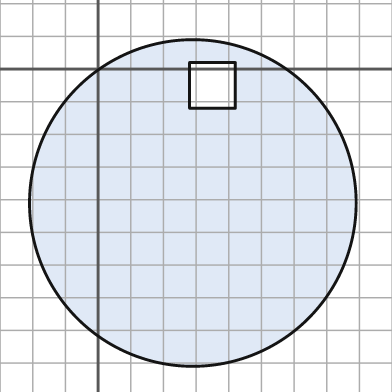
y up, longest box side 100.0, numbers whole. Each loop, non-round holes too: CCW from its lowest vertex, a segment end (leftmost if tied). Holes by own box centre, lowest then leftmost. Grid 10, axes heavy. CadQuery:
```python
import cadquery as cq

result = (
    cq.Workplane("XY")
    .moveTo(29.0, -41.0)
    .circle(50.0)
    .moveTo(28.0, -12.0)
    .lineTo(42.0, -12.0)
    .lineTo(42.0, 2.0)
    .lineTo(28.0, 2.0)
    .close()
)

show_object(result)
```